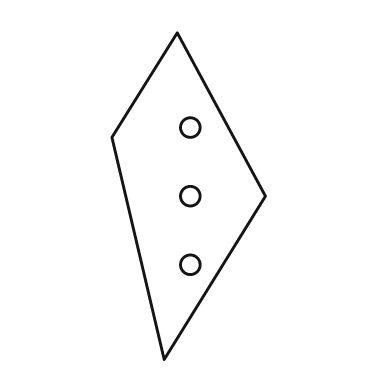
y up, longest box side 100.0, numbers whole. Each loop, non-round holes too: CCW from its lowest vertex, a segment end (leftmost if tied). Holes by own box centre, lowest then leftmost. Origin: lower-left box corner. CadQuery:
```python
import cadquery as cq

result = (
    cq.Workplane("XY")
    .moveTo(16.0, 0.0)
    .lineTo(47.0, 50.0)
    .lineTo(20.0, 100.0)
    .lineTo(0.0, 68.0)
    .close()
    .moveTo(24.0, 29.0)
    .circle(3.0)
    .moveTo(24.0, 50.0)
    .circle(3.0)
    .moveTo(24.0, 71.0)
    .circle(3.0)
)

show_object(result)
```